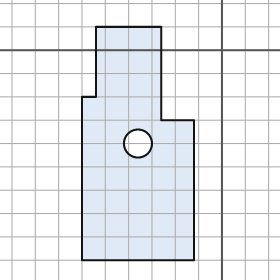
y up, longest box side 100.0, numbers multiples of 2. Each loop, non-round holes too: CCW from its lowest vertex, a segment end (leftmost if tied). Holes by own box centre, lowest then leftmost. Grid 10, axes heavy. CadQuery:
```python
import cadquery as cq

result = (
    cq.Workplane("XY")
    .moveTo(-60.0, -90.0)
    .lineTo(-12.0, -90.0)
    .lineTo(-12.0, -30.0)
    .lineTo(-26.0, -30.0)
    .lineTo(-26.0, 10.0)
    .lineTo(-54.0, 10.0)
    .lineTo(-54.0, -20.0)
    .lineTo(-60.0, -20.0)
    .close()
    .moveTo(-36.0, -40.0)
    .circle(6.0)
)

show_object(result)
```